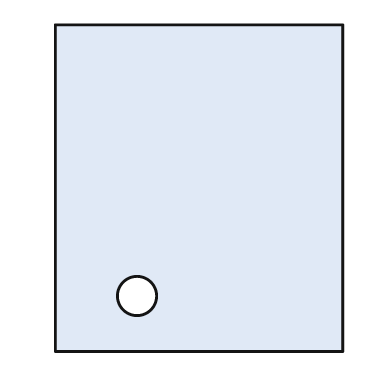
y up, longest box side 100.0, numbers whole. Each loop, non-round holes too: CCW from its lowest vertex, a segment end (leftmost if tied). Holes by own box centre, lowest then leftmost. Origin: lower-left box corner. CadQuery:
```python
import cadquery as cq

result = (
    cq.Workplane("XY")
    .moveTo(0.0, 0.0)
    .lineTo(88.0, 0.0)
    .lineTo(88.0, 100.0)
    .lineTo(0.0, 100.0)
    .close()
    .moveTo(25.0, 17.0)
    .circle(6.0)
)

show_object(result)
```